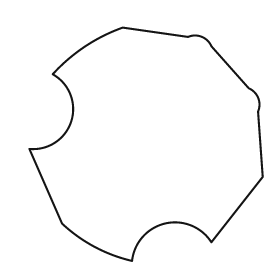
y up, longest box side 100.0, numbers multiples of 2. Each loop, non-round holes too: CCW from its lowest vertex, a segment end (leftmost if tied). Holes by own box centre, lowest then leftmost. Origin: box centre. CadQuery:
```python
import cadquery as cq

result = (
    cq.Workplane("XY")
    .moveTo(-6.0, -50.0)
    .threePointArc((8.0, -34.0), (28.0, -42.0))
    .lineTo(50.0, -14.0)
    .lineTo(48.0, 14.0)
    .threePointArc((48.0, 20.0), (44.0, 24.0))
    .lineTo(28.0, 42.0)
    .threePointArc((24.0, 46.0), (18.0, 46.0))
    .lineTo(-10.0, 50.0)
    .threePointArc((-26.0, 42.0), (-40.0, 30.0))
    .threePointArc((-32.0, 10.0), (-50.0, -2.0))
    .lineTo(-36.0, -34.0)
    .threePointArc((-22.0, -44.0), (-6.0, -50.0))
    .close()
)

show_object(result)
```